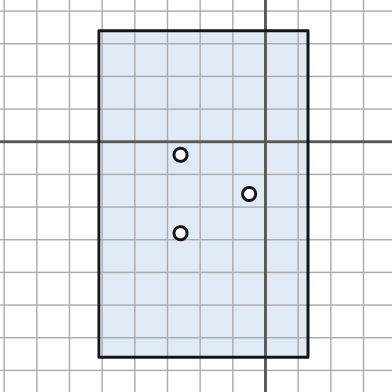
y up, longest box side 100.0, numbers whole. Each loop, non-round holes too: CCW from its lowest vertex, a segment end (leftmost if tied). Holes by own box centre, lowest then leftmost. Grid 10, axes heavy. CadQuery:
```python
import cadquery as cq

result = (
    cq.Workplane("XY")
    .moveTo(-51.0, -66.0)
    .lineTo(13.0, -66.0)
    .lineTo(13.0, 34.0)
    .lineTo(-51.0, 34.0)
    .close()
    .moveTo(-26.0, -28.0)
    .circle(2.0)
    .moveTo(-5.0, -16.0)
    .circle(2.0)
    .moveTo(-26.0, -4.0)
    .circle(2.0)
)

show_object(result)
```